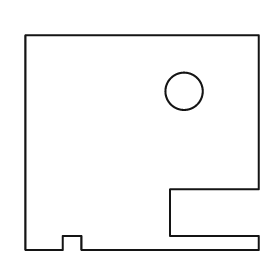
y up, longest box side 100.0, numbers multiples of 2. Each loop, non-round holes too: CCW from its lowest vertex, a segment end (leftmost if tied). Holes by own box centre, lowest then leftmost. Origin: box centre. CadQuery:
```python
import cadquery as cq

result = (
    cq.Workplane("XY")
    .moveTo(-50.0, -46.0)
    .lineTo(-34.0, -46.0)
    .lineTo(-34.0, -40.0)
    .lineTo(-26.0, -40.0)
    .lineTo(-26.0, -46.0)
    .lineTo(50.0, -46.0)
    .lineTo(50.0, -40.0)
    .lineTo(12.0, -40.0)
    .lineTo(12.0, -20.0)
    .lineTo(50.0, -20.0)
    .lineTo(50.0, 46.0)
    .lineTo(-50.0, 46.0)
    .close()
    .moveTo(18.0, 22.0)
    .circle(8.0)
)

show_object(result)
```